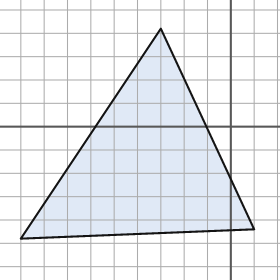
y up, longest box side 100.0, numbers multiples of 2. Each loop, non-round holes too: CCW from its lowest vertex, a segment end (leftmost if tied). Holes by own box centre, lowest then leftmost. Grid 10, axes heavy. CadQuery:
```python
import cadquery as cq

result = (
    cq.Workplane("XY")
    .moveTo(-90.0, -48.0)
    .lineTo(10.0, -44.0)
    .lineTo(-30.0, 42.0)
    .close()
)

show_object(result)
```